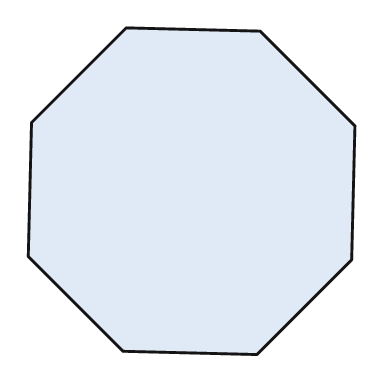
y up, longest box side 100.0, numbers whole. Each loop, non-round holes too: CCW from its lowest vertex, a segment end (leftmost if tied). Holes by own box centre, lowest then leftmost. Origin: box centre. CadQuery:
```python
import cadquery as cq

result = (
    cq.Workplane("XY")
    .moveTo(20.0, -50.0)
    .lineTo(49.0, -21.0)
    .lineTo(50.0, 20.0)
    .lineTo(21.0, 49.0)
    .lineTo(-20.0, 50.0)
    .lineTo(-49.0, 21.0)
    .lineTo(-50.0, -20.0)
    .lineTo(-21.0, -49.0)
    .close()
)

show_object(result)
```